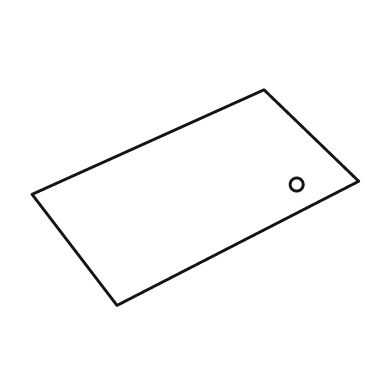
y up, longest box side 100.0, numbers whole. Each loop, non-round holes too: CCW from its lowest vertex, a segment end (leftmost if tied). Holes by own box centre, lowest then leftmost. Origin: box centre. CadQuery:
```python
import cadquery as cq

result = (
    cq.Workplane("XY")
    .moveTo(-24.0, -33.0)
    .lineTo(50.0, 5.0)
    .lineTo(21.0, 33.0)
    .lineTo(-50.0, 1.0)
    .close()
    .moveTo(31.0, 4.0)
    .circle(2.0)
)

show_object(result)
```